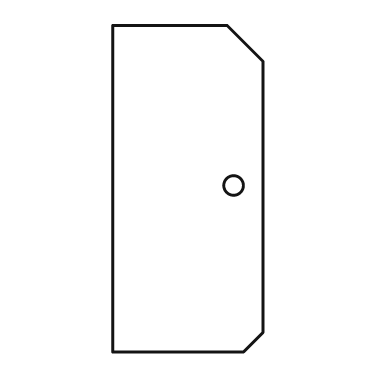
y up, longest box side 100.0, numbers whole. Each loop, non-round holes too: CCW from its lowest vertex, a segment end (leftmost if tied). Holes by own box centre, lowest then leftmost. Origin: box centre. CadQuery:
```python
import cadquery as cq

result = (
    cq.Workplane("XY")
    .moveTo(-23.0, -50.0)
    .lineTo(17.0, -50.0)
    .lineTo(23.0, -44.0)
    .lineTo(23.0, 39.0)
    .lineTo(12.0, 50.0)
    .lineTo(-23.0, 50.0)
    .close()
    .moveTo(14.0, 1.0)
    .circle(3.0)
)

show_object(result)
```